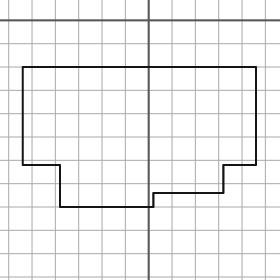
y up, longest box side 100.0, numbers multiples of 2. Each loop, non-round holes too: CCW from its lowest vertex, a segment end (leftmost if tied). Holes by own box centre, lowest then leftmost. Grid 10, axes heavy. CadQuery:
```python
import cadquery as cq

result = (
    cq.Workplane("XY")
    .moveTo(-38.0, -80.0)
    .lineTo(2.0, -80.0)
    .lineTo(2.0, -74.0)
    .lineTo(32.0, -74.0)
    .lineTo(32.0, -62.0)
    .lineTo(46.0, -62.0)
    .lineTo(46.0, -20.0)
    .lineTo(-54.0, -20.0)
    .lineTo(-54.0, -62.0)
    .lineTo(-38.0, -62.0)
    .close()
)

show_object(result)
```